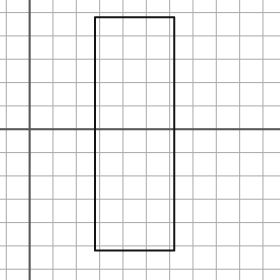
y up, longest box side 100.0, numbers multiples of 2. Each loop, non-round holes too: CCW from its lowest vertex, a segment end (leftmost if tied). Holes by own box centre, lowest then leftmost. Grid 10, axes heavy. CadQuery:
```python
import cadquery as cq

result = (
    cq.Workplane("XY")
    .moveTo(28.0, -52.0)
    .lineTo(62.0, -52.0)
    .lineTo(62.0, 48.0)
    .lineTo(28.0, 48.0)
    .close()
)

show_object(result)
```